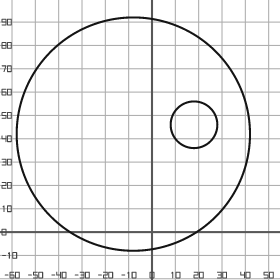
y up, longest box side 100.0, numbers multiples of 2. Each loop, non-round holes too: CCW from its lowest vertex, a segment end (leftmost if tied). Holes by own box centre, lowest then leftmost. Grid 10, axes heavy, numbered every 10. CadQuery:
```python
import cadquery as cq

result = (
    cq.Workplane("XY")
    .moveTo(-8.0, 42.0)
    .circle(50.0)
    .moveTo(18.0, 46.0)
    .circle(10.0)
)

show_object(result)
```